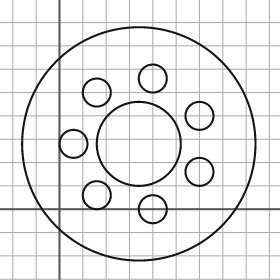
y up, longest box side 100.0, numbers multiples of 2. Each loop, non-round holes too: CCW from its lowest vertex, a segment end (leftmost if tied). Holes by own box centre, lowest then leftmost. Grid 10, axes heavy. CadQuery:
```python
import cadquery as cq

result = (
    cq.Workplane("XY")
    .moveTo(34.0, 28.0)
    .circle(50.0)
    .moveTo(40.0, 0.0)
    .circle(6.0)
    .moveTo(16.0, 6.0)
    .circle(6.0)
    .moveTo(60.0, 16.0)
    .circle(6.0)
    .moveTo(6.0, 28.0)
    .circle(6.0)
    .moveTo(34.0, 28.0)
    .circle(18.0)
    .moveTo(60.0, 40.0)
    .circle(6.0)
    .moveTo(16.0, 50.0)
    .circle(6.0)
    .moveTo(40.0, 56.0)
    .circle(6.0)
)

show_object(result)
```